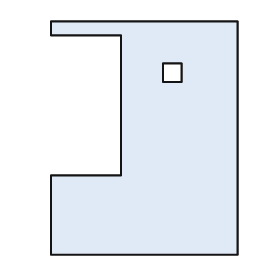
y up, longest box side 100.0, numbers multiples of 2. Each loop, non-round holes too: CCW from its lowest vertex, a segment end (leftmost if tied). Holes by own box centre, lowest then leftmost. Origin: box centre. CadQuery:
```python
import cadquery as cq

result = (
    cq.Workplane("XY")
    .moveTo(-40.0, -50.0)
    .lineTo(40.0, -50.0)
    .lineTo(40.0, 50.0)
    .lineTo(-40.0, 50.0)
    .lineTo(-40.0, 44.0)
    .lineTo(-10.0, 44.0)
    .lineTo(-10.0, -16.0)
    .lineTo(-40.0, -16.0)
    .close()
    .moveTo(8.0, 24.0)
    .lineTo(16.0, 24.0)
    .lineTo(16.0, 32.0)
    .lineTo(8.0, 32.0)
    .close()
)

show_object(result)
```